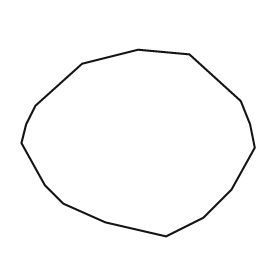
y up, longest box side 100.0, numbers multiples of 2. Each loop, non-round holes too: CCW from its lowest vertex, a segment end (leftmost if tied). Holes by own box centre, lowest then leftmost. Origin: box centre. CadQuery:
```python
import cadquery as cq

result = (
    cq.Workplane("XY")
    .moveTo(12.0, -40.0)
    .lineTo(28.0, -32.0)
    .lineTo(40.0, -20.0)
    .lineTo(50.0, -2.0)
    .lineTo(48.0, 8.0)
    .lineTo(44.0, 18.0)
    .lineTo(22.0, 38.0)
    .lineTo(0.0, 40.0)
    .lineTo(-24.0, 34.0)
    .lineTo(-44.0, 16.0)
    .lineTo(-48.0, 8.0)
    .lineTo(-50.0, 0.0)
    .lineTo(-40.0, -18.0)
    .lineTo(-32.0, -26.0)
    .lineTo(-14.0, -34.0)
    .close()
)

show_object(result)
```